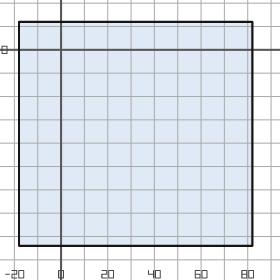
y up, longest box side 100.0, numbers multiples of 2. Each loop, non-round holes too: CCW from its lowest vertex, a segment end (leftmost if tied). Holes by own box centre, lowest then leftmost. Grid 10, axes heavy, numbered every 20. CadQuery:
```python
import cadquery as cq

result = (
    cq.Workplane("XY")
    .moveTo(-18.0, -84.0)
    .lineTo(82.0, -84.0)
    .lineTo(82.0, 12.0)
    .lineTo(-18.0, 12.0)
    .close()
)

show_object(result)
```